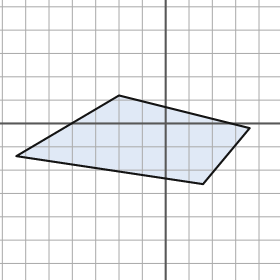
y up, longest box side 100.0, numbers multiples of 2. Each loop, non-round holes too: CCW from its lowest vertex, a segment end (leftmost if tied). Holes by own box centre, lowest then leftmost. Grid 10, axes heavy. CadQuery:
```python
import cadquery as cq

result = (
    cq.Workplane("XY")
    .moveTo(16.0, -26.0)
    .lineTo(36.0, -2.0)
    .lineTo(-20.0, 12.0)
    .lineTo(-64.0, -14.0)
    .close()
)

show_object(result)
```